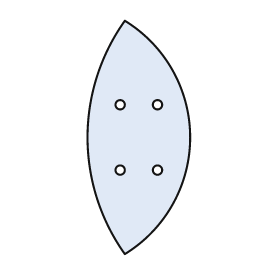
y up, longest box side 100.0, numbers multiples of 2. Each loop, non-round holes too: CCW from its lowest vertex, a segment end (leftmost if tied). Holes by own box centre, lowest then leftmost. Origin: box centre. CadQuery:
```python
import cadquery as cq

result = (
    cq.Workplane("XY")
    .moveTo(-6.0, -50.0)
    .threePointArc((22.0, 0.0), (-6.0, 50.0))
    .threePointArc((-22.0, 0.0), (-6.0, -50.0))
    .close()
    .moveTo(-8.0, -14.0)
    .circle(2.0)
    .moveTo(8.0, -14.0)
    .circle(2.0)
    .moveTo(-8.0, 14.0)
    .circle(2.0)
    .moveTo(8.0, 14.0)
    .circle(2.0)
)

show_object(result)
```